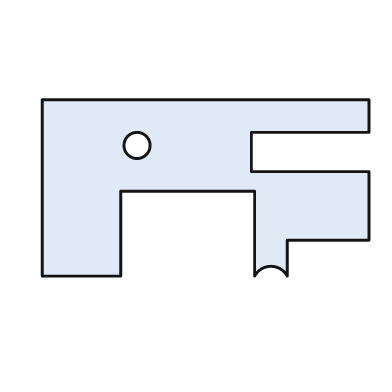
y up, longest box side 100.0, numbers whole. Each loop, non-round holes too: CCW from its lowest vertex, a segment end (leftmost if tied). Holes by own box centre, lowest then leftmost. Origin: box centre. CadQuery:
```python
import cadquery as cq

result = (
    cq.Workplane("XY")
    .moveTo(-50.0, -27.0)
    .lineTo(-26.0, -27.0)
    .lineTo(-26.0, -1.0)
    .lineTo(15.0, -1.0)
    .lineTo(15.0, -27.0)
    .threePointArc((20.0, -24.0), (25.0, -27.0))
    .lineTo(25.0, -16.0)
    .lineTo(50.0, -16.0)
    .lineTo(50.0, 5.0)
    .lineTo(14.0, 5.0)
    .lineTo(14.0, 17.0)
    .lineTo(50.0, 17.0)
    .lineTo(50.0, 27.0)
    .lineTo(-50.0, 27.0)
    .close()
    .moveTo(-21.0, 13.0)
    .circle(4.0)
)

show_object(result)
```